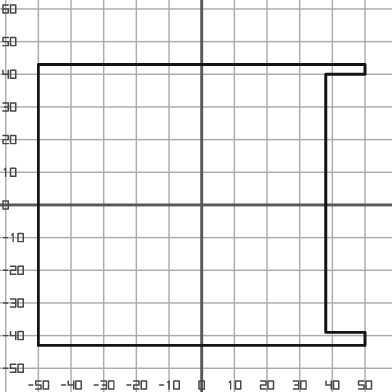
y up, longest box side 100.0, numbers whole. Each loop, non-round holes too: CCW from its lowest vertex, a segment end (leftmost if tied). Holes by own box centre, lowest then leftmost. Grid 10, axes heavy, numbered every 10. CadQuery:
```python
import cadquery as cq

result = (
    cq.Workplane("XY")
    .moveTo(-50.0, -43.0)
    .lineTo(50.0, -43.0)
    .lineTo(50.0, -39.0)
    .lineTo(38.0, -39.0)
    .lineTo(38.0, 40.0)
    .lineTo(50.0, 40.0)
    .lineTo(50.0, 43.0)
    .lineTo(-50.0, 43.0)
    .close()
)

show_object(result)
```